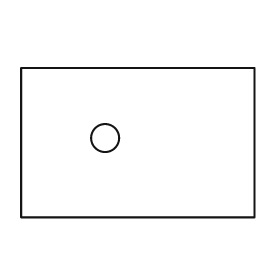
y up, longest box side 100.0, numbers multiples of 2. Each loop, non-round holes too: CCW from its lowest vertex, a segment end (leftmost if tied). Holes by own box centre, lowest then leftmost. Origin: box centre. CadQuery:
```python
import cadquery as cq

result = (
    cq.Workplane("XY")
    .moveTo(-50.0, -32.0)
    .lineTo(50.0, -32.0)
    .lineTo(50.0, 32.0)
    .lineTo(-50.0, 32.0)
    .close()
    .moveTo(-14.0, 2.0)
    .circle(6.0)
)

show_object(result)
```